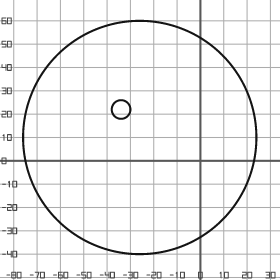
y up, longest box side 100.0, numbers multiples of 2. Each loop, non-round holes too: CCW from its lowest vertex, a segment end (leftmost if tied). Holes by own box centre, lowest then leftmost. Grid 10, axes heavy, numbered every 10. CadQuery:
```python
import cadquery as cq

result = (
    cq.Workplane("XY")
    .moveTo(-26.0, 10.0)
    .circle(50.0)
    .moveTo(-34.0, 22.0)
    .circle(4.0)
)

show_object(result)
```